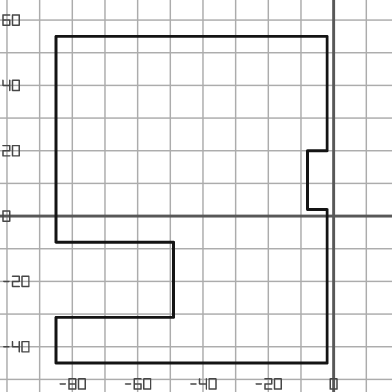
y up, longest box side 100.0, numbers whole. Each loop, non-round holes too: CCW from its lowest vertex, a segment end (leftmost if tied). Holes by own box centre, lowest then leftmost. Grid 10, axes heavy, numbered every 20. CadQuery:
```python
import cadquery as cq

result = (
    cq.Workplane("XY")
    .moveTo(-85.0, -45.0)
    .lineTo(-2.0, -45.0)
    .lineTo(-2.0, 2.0)
    .lineTo(-8.0, 2.0)
    .lineTo(-8.0, 20.0)
    .lineTo(-2.0, 20.0)
    .lineTo(-2.0, 55.0)
    .lineTo(-85.0, 55.0)
    .lineTo(-85.0, -8.0)
    .lineTo(-49.0, -8.0)
    .lineTo(-49.0, -31.0)
    .lineTo(-85.0, -31.0)
    .close()
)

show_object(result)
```